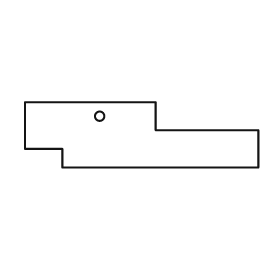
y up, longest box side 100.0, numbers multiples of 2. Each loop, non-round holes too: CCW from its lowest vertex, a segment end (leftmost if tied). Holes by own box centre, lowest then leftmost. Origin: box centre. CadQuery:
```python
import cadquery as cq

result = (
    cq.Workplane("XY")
    .moveTo(-34.0, -14.0)
    .lineTo(50.0, -14.0)
    .lineTo(50.0, 2.0)
    .lineTo(6.0, 2.0)
    .lineTo(6.0, 14.0)
    .lineTo(-50.0, 14.0)
    .lineTo(-50.0, -6.0)
    .lineTo(-34.0, -6.0)
    .close()
    .moveTo(-18.0, 8.0)
    .circle(2.0)
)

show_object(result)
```